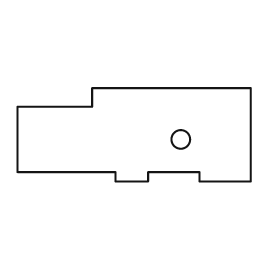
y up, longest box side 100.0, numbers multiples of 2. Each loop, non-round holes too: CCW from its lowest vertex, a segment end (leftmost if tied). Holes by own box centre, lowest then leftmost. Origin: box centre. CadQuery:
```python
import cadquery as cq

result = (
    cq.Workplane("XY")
    .moveTo(-8.0, -20.0)
    .lineTo(6.0, -20.0)
    .lineTo(6.0, -16.0)
    .lineTo(28.0, -16.0)
    .lineTo(28.0, -20.0)
    .lineTo(50.0, -20.0)
    .lineTo(50.0, 20.0)
    .lineTo(-18.0, 20.0)
    .lineTo(-18.0, 12.0)
    .lineTo(-50.0, 12.0)
    .lineTo(-50.0, -16.0)
    .lineTo(-8.0, -16.0)
    .close()
    .moveTo(20.0, -2.0)
    .circle(4.0)
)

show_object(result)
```